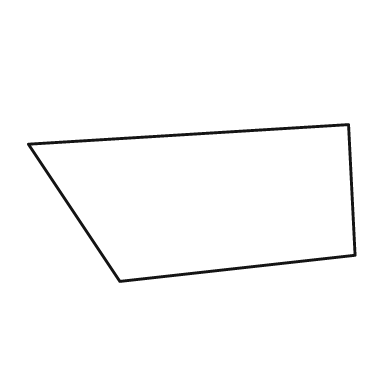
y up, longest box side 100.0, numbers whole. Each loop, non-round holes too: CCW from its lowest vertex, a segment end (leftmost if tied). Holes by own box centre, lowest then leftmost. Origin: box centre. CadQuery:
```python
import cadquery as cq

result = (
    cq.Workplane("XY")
    .moveTo(-22.0, -24.0)
    .lineTo(50.0, -16.0)
    .lineTo(48.0, 24.0)
    .lineTo(-50.0, 18.0)
    .close()
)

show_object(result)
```